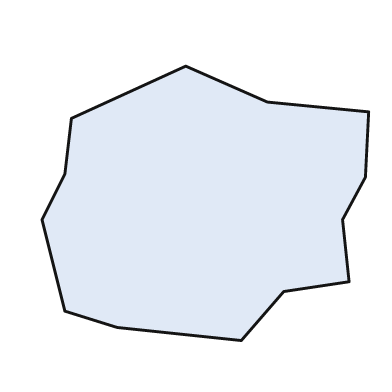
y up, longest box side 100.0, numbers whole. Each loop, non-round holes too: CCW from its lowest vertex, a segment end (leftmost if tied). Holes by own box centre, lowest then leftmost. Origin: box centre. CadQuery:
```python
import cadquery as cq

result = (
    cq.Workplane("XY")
    .moveTo(11.0, -42.0)
    .lineTo(24.0, -27.0)
    .lineTo(44.0, -24.0)
    .lineTo(42.0, -5.0)
    .lineTo(49.0, 8.0)
    .lineTo(50.0, 28.0)
    .lineTo(19.0, 31.0)
    .lineTo(-6.0, 42.0)
    .lineTo(-41.0, 26.0)
    .lineTo(-43.0, 9.0)
    .lineTo(-50.0, -5.0)
    .lineTo(-43.0, -33.0)
    .lineTo(-27.0, -38.0)
    .close()
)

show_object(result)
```